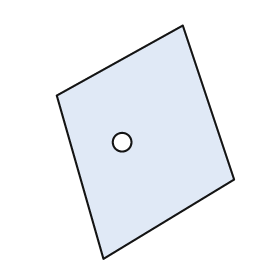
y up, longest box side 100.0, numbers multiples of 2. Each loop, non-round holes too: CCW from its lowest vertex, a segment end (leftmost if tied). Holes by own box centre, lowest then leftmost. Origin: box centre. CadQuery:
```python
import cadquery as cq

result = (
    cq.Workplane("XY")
    .moveTo(-18.0, -50.0)
    .lineTo(38.0, -16.0)
    .lineTo(16.0, 50.0)
    .lineTo(-38.0, 20.0)
    .close()
    .moveTo(-10.0, 0.0)
    .circle(4.0)
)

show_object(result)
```